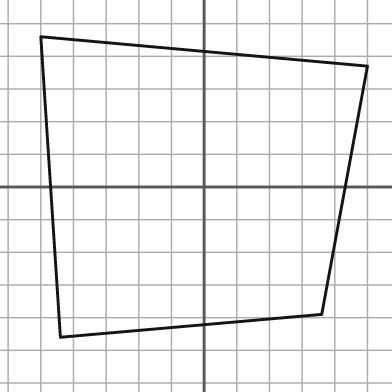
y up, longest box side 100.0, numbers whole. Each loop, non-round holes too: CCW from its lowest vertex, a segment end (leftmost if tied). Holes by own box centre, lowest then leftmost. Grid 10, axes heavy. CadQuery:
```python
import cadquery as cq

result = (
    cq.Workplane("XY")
    .moveTo(-44.0, -46.0)
    .lineTo(36.0, -39.0)
    .lineTo(50.0, 37.0)
    .lineTo(-50.0, 46.0)
    .close()
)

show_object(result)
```